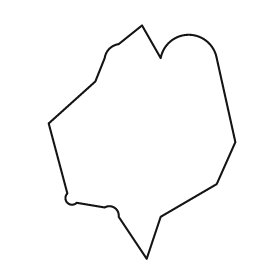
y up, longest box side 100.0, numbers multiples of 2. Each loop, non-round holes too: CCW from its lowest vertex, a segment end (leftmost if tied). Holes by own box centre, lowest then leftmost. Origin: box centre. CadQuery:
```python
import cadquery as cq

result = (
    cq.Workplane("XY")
    .moveTo(2.0, -50.0)
    .lineTo(8.0, -32.0)
    .lineTo(32.0, -18.0)
    .lineTo(40.0, 0.0)
    .lineTo(32.0, 36.0)
    .threePointArc((20.0, 46.0), (8.0, 36.0))
    .lineTo(0.0, 50.0)
    .lineTo(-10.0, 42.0)
    .threePointArc((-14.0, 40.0), (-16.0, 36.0))
    .lineTo(-20.0, 26.0)
    .lineTo(-40.0, 8.0)
    .lineTo(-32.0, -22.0)
    .threePointArc((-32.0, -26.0), (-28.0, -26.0))
    .lineTo(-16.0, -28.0)
    .threePointArc((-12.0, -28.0), (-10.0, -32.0))
    .close()
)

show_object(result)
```